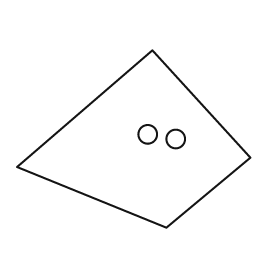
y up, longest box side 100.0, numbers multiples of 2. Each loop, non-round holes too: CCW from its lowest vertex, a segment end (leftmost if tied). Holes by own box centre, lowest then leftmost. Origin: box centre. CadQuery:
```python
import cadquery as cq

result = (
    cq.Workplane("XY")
    .moveTo(14.0, -38.0)
    .lineTo(50.0, -8.0)
    .lineTo(8.0, 38.0)
    .lineTo(-50.0, -12.0)
    .close()
    .moveTo(18.0, 0.0)
    .circle(4.0)
    .moveTo(6.0, 2.0)
    .circle(4.0)
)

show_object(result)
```